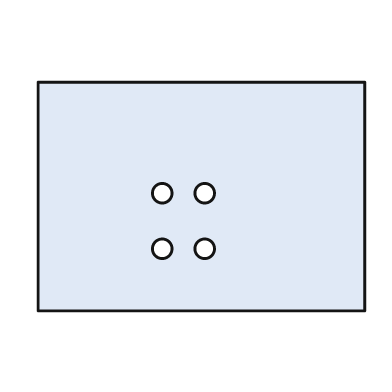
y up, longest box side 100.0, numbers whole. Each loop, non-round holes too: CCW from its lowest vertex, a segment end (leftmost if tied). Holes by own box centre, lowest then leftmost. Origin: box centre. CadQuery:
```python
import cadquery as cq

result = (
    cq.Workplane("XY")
    .moveTo(-50.0, -35.0)
    .lineTo(50.0, -35.0)
    .lineTo(50.0, 35.0)
    .lineTo(-50.0, 35.0)
    .close()
    .moveTo(-12.0, -16.0)
    .circle(3.0)
    .moveTo(1.0, -16.0)
    .circle(3.0)
    .moveTo(-12.0, 1.0)
    .circle(3.0)
    .moveTo(1.0, 1.0)
    .circle(3.0)
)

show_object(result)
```